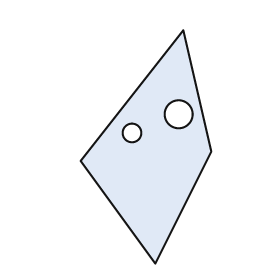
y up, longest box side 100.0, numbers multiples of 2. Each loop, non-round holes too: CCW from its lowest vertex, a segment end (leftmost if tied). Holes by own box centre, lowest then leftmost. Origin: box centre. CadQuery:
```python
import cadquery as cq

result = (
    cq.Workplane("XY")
    .moveTo(4.0, -50.0)
    .lineTo(28.0, -2.0)
    .lineTo(16.0, 50.0)
    .lineTo(-28.0, -6.0)
    .close()
    .moveTo(-6.0, 6.0)
    .circle(4.0)
    .moveTo(14.0, 14.0)
    .circle(6.0)
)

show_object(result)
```